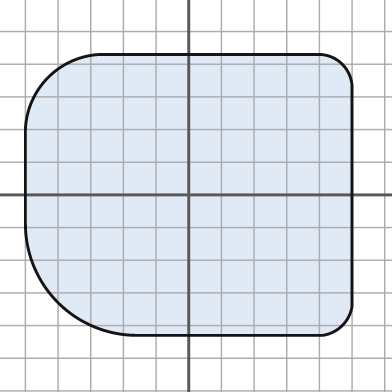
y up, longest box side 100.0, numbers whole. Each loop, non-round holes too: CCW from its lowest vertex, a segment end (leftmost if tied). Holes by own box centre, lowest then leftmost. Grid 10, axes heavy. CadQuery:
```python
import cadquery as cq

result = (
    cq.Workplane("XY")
    .moveTo(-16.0, -43.0)
    .lineTo(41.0, -43.0)
    .threePointArc((47.0, -40.0), (50.0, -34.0))
    .lineTo(50.0, 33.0)
    .threePointArc((47.0, 40.0), (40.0, 43.0))
    .lineTo(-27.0, 43.0)
    .threePointArc((-43.0, 36.0), (-50.0, 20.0))
    .lineTo(-50.0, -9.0)
    .threePointArc((-40.0, -33.0), (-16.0, -43.0))
    .close()
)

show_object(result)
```